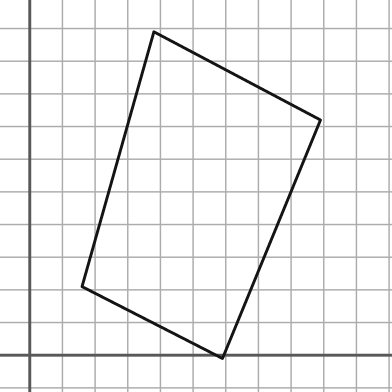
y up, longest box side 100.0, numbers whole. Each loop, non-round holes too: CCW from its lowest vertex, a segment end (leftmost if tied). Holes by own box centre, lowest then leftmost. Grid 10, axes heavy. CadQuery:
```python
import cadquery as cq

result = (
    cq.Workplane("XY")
    .moveTo(59.0, -1.0)
    .lineTo(89.0, 72.0)
    .lineTo(38.0, 99.0)
    .lineTo(16.0, 21.0)
    .close()
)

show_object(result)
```